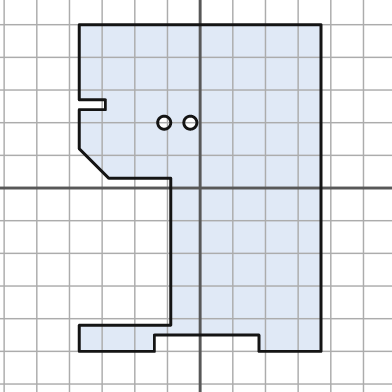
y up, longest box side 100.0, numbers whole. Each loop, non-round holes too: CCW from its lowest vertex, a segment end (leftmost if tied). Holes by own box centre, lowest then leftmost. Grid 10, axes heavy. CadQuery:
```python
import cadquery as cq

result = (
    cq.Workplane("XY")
    .moveTo(-37.0, -50.0)
    .lineTo(-14.0, -50.0)
    .lineTo(-14.0, -45.0)
    .lineTo(18.0, -45.0)
    .lineTo(18.0, -50.0)
    .lineTo(37.0, -50.0)
    .lineTo(37.0, 50.0)
    .lineTo(-37.0, 50.0)
    .lineTo(-37.0, 27.0)
    .lineTo(-29.0, 27.0)
    .lineTo(-29.0, 24.0)
    .lineTo(-37.0, 24.0)
    .lineTo(-37.0, 12.0)
    .lineTo(-28.0, 3.0)
    .lineTo(-9.0, 3.0)
    .lineTo(-9.0, -42.0)
    .lineTo(-37.0, -42.0)
    .close()
    .moveTo(-11.0, 20.0)
    .circle(2.0)
    .moveTo(-3.0, 20.0)
    .circle(2.0)
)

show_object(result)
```